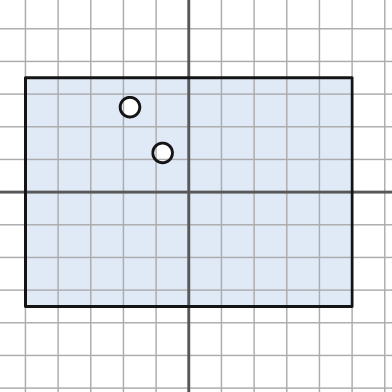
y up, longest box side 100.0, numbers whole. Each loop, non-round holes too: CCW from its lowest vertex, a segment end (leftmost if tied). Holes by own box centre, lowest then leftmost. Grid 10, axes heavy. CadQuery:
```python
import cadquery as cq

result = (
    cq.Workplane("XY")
    .moveTo(-50.0, -35.0)
    .lineTo(50.0, -35.0)
    .lineTo(50.0, 35.0)
    .lineTo(-50.0, 35.0)
    .close()
    .moveTo(-8.0, 12.0)
    .circle(3.0)
    .moveTo(-18.0, 26.0)
    .circle(3.0)
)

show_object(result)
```